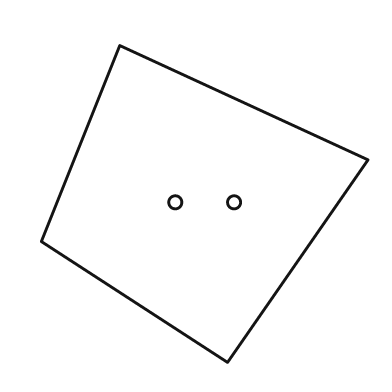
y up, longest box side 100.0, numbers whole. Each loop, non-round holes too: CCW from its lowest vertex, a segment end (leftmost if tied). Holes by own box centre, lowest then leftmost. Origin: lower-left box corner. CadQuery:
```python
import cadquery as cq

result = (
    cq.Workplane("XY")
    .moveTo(57.0, 0.0)
    .lineTo(100.0, 62.0)
    .lineTo(24.0, 97.0)
    .lineTo(0.0, 37.0)
    .close()
    .moveTo(41.0, 49.0)
    .circle(2.0)
    .moveTo(59.0, 49.0)
    .circle(2.0)
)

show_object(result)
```